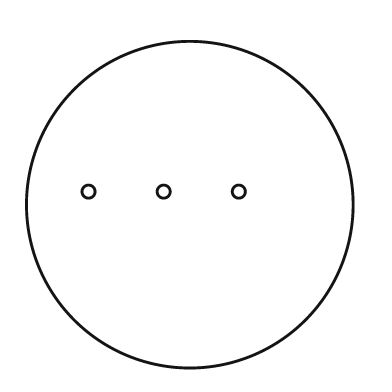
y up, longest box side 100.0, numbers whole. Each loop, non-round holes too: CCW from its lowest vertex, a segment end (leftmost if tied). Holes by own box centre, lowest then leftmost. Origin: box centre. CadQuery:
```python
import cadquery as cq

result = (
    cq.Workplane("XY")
    .moveTo(0.0, 0.0)
    .circle(50.0)
    .moveTo(-31.0, 4.0)
    .circle(2.0)
    .moveTo(-8.0, 4.0)
    .circle(2.0)
    .moveTo(15.0, 4.0)
    .circle(2.0)
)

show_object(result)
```